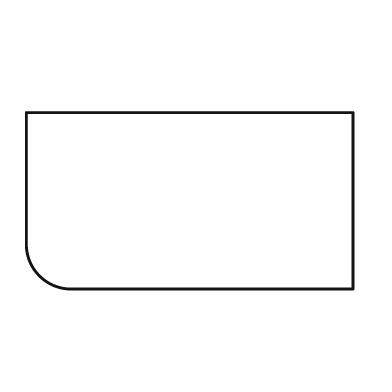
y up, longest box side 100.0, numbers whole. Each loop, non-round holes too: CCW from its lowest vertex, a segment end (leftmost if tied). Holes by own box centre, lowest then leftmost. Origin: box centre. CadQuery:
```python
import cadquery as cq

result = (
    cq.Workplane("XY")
    .moveTo(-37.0, -27.0)
    .lineTo(50.0, -27.0)
    .lineTo(50.0, 27.0)
    .lineTo(-50.0, 27.0)
    .lineTo(-50.0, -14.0)
    .threePointArc((-46.0, -23.0), (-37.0, -27.0))
    .close()
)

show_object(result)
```